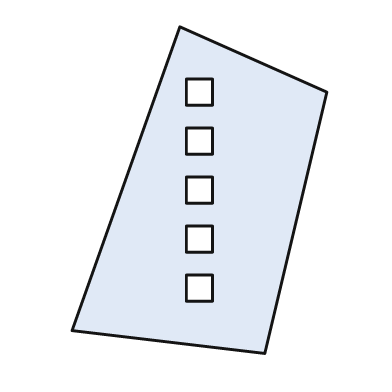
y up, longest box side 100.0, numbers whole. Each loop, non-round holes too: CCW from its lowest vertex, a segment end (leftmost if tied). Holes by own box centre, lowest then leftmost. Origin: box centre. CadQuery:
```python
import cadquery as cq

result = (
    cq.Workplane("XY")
    .moveTo(20.0, -50.0)
    .lineTo(39.0, 30.0)
    .lineTo(-6.0, 50.0)
    .lineTo(-39.0, -43.0)
    .close()
    .moveTo(-4.0, -34.0)
    .lineTo(4.0, -34.0)
    .lineTo(4.0, -26.0)
    .lineTo(-4.0, -26.0)
    .close()
    .moveTo(-4.0, -19.0)
    .lineTo(4.0, -19.0)
    .lineTo(4.0, -11.0)
    .lineTo(-4.0, -11.0)
    .close()
    .moveTo(-4.0, -4.0)
    .lineTo(4.0, -4.0)
    .lineTo(4.0, 4.0)
    .lineTo(-4.0, 4.0)
    .close()
    .moveTo(-4.0, 11.0)
    .lineTo(4.0, 11.0)
    .lineTo(4.0, 19.0)
    .lineTo(-4.0, 19.0)
    .close()
    .moveTo(-4.0, 26.0)
    .lineTo(4.0, 26.0)
    .lineTo(4.0, 34.0)
    .lineTo(-4.0, 34.0)
    .close()
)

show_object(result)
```